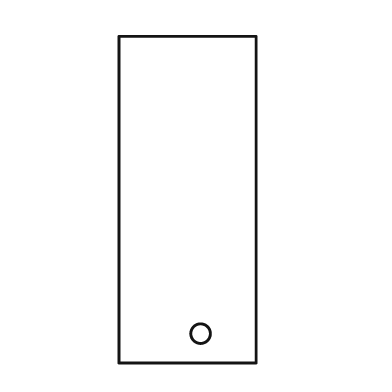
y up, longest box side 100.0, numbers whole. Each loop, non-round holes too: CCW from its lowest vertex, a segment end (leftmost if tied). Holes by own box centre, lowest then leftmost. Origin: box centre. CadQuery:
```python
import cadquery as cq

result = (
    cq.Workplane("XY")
    .moveTo(-21.0, -50.0)
    .lineTo(21.0, -50.0)
    .lineTo(21.0, 50.0)
    .lineTo(-21.0, 50.0)
    .close()
    .moveTo(4.0, -41.0)
    .circle(3.0)
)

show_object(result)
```